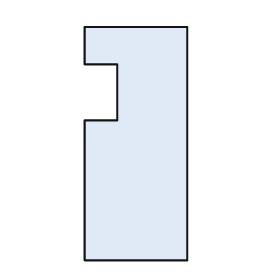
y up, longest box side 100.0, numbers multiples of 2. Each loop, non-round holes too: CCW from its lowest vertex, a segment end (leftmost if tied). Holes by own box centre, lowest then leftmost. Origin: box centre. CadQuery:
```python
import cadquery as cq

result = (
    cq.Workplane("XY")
    .moveTo(-22.0, -50.0)
    .lineTo(22.0, -50.0)
    .lineTo(22.0, 50.0)
    .lineTo(-22.0, 50.0)
    .lineTo(-22.0, 34.0)
    .lineTo(-8.0, 34.0)
    .lineTo(-8.0, 10.0)
    .lineTo(-22.0, 10.0)
    .close()
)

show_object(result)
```